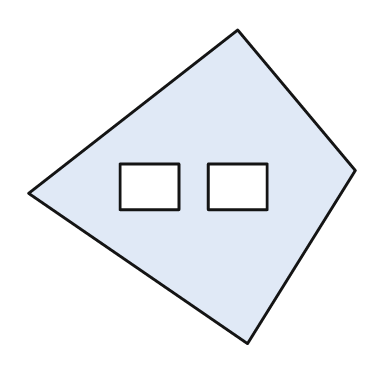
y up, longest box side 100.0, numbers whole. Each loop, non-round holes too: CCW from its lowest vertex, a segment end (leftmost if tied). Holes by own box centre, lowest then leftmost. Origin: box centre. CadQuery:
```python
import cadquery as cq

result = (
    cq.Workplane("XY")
    .moveTo(17.0, -48.0)
    .lineTo(50.0, 5.0)
    .lineTo(14.0, 48.0)
    .lineTo(-50.0, -2.0)
    .close()
    .moveTo(-22.0, -7.0)
    .lineTo(-4.0, -7.0)
    .lineTo(-4.0, 7.0)
    .lineTo(-22.0, 7.0)
    .close()
    .moveTo(5.0, -7.0)
    .lineTo(23.0, -7.0)
    .lineTo(23.0, 7.0)
    .lineTo(5.0, 7.0)
    .close()
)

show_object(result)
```